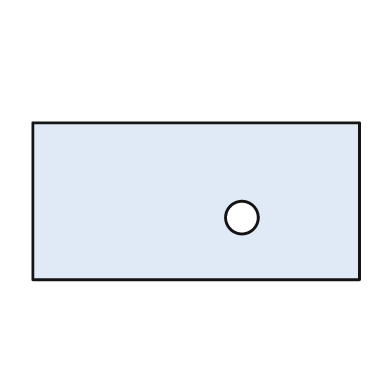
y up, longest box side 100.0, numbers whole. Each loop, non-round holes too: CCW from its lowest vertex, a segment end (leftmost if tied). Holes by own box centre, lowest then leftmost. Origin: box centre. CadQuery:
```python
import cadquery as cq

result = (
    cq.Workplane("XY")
    .moveTo(-50.0, -24.0)
    .lineTo(50.0, -24.0)
    .lineTo(50.0, 24.0)
    .lineTo(-50.0, 24.0)
    .close()
    .moveTo(14.0, -5.0)
    .circle(5.0)
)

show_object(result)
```